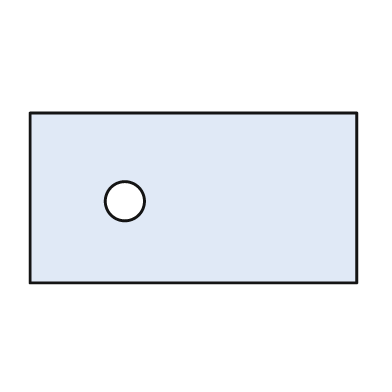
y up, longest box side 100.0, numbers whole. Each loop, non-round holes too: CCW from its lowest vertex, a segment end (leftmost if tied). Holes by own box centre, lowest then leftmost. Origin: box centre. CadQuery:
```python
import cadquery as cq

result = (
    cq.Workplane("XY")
    .moveTo(-50.0, -26.0)
    .lineTo(50.0, -26.0)
    .lineTo(50.0, 26.0)
    .lineTo(-50.0, 26.0)
    .close()
    .moveTo(-21.0, -1.0)
    .circle(6.0)
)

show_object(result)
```